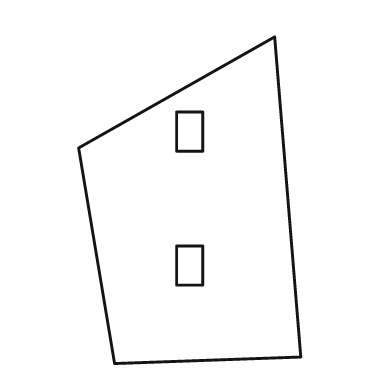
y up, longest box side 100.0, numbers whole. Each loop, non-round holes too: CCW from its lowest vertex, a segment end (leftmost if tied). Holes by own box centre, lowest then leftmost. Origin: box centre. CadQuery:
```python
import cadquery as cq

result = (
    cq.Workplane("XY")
    .moveTo(-23.0, -50.0)
    .lineTo(34.0, -48.0)
    .lineTo(26.0, 50.0)
    .lineTo(-34.0, 16.0)
    .close()
    .moveTo(-4.0, -26.0)
    .lineTo(4.0, -26.0)
    .lineTo(4.0, -14.0)
    .lineTo(-4.0, -14.0)
    .close()
    .moveTo(-4.0, 15.0)
    .lineTo(4.0, 15.0)
    .lineTo(4.0, 27.0)
    .lineTo(-4.0, 27.0)
    .close()
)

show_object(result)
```